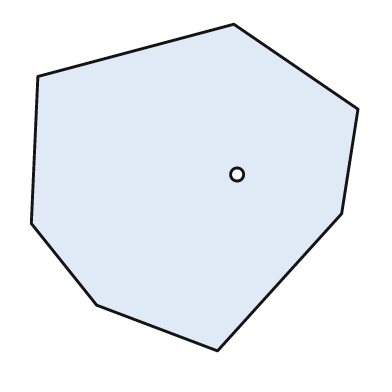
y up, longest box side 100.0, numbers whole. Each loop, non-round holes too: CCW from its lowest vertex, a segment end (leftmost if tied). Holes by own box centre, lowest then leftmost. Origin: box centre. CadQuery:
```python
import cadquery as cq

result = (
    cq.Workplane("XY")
    .moveTo(7.0, -50.0)
    .lineTo(45.0, -8.0)
    .lineTo(50.0, 24.0)
    .lineTo(12.0, 50.0)
    .lineTo(-48.0, 34.0)
    .lineTo(-50.0, -11.0)
    .lineTo(-30.0, -36.0)
    .close()
    .moveTo(13.0, 4.0)
    .circle(2.0)
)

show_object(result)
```